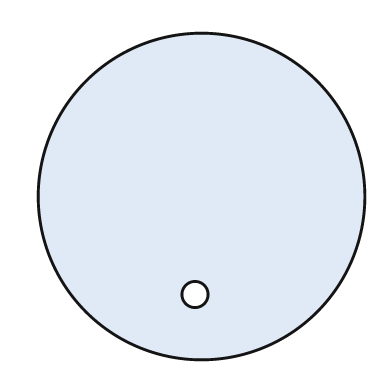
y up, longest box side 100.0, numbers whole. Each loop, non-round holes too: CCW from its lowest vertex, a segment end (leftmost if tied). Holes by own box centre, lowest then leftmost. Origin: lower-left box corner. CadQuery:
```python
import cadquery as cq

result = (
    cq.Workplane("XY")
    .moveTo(50.0, 50.0)
    .circle(50.0)
    .moveTo(48.0, 20.0)
    .circle(4.0)
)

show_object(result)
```